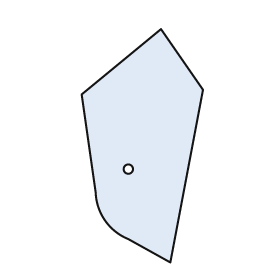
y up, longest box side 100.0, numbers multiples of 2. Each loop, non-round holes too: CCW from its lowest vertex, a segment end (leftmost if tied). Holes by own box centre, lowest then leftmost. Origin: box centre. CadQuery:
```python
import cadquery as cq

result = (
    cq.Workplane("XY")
    .moveTo(12.0, -50.0)
    .lineTo(26.0, 24.0)
    .lineTo(8.0, 50.0)
    .lineTo(-26.0, 22.0)
    .lineTo(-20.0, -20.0)
    .threePointArc((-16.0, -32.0), (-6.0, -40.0))
    .close()
    .moveTo(-6.0, -10.0)
    .circle(2.0)
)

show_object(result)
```